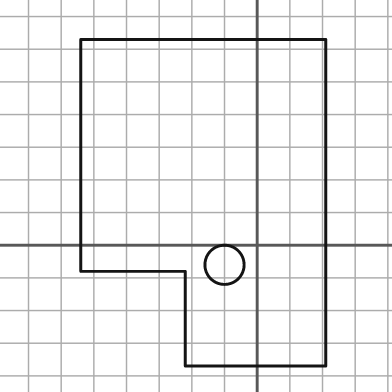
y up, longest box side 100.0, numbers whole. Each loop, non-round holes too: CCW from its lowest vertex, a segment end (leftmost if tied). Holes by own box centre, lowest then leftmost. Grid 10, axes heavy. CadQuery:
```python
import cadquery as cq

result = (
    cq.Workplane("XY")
    .moveTo(-22.0, -37.0)
    .lineTo(21.0, -37.0)
    .lineTo(21.0, 63.0)
    .lineTo(-54.0, 63.0)
    .lineTo(-54.0, -8.0)
    .lineTo(-22.0, -8.0)
    .close()
    .moveTo(-10.0, -6.0)
    .circle(6.0)
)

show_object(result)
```